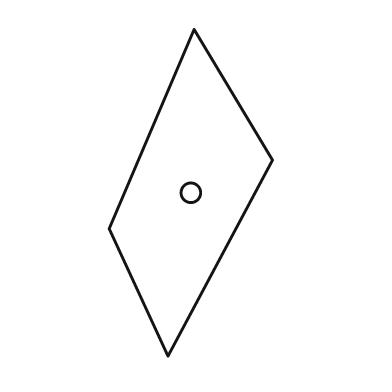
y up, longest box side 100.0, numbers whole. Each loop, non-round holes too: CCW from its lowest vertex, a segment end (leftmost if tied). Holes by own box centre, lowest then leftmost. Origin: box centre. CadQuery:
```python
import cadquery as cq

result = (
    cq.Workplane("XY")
    .moveTo(-7.0, -50.0)
    .lineTo(25.0, 10.0)
    .lineTo(1.0, 50.0)
    .lineTo(-25.0, -11.0)
    .close()
    .moveTo(0.0, 0.0)
    .circle(3.0)
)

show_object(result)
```